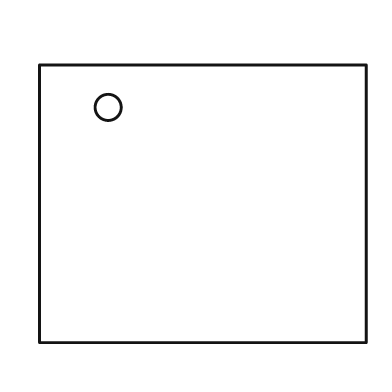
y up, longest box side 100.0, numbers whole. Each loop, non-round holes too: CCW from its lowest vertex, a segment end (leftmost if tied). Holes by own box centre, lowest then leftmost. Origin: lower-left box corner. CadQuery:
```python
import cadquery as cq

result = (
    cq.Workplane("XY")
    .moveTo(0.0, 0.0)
    .lineTo(100.0, 0.0)
    .lineTo(100.0, 85.0)
    .lineTo(0.0, 85.0)
    .close()
    .moveTo(21.0, 72.0)
    .circle(4.0)
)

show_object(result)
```